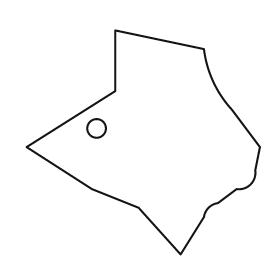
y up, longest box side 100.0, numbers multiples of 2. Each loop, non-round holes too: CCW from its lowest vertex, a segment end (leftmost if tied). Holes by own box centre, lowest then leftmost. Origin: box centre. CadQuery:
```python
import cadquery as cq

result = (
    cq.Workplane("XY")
    .moveTo(16.0, -48.0)
    .lineTo(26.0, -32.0)
    .threePointArc((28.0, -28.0), (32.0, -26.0))
    .lineTo(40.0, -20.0)
    .threePointArc((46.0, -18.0), (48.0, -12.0))
    .lineTo(50.0, -2.0)
    .lineTo(38.0, 14.0)
    .threePointArc((30.0, 26.0), (26.0, 40.0))
    .lineTo(-12.0, 48.0)
    .lineTo(-12.0, 22.0)
    .lineTo(-50.0, -2.0)
    .lineTo(-22.0, -20.0)
    .lineTo(-2.0, -28.0)
    .close()
    .moveTo(-20.0, 6.0)
    .circle(4.0)
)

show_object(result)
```